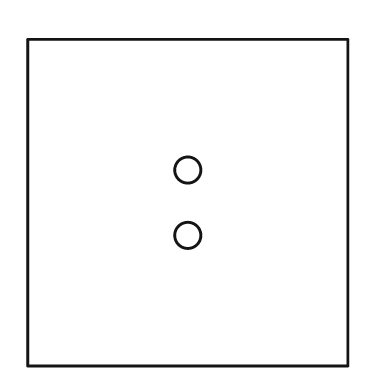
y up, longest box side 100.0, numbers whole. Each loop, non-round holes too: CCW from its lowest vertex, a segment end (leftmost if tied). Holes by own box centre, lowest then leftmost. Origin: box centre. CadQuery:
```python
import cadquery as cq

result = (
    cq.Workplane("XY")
    .moveTo(-49.0, -50.0)
    .lineTo(49.0, -50.0)
    .lineTo(49.0, 50.0)
    .lineTo(-49.0, 50.0)
    .close()
    .moveTo(0.0, -10.0)
    .circle(4.0)
    .moveTo(0.0, 10.0)
    .circle(4.0)
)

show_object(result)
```